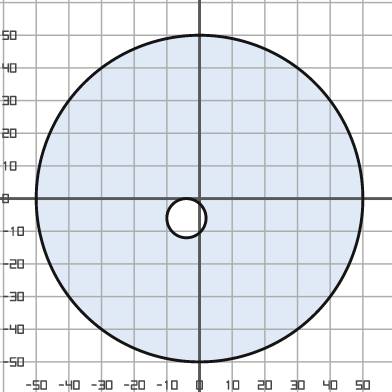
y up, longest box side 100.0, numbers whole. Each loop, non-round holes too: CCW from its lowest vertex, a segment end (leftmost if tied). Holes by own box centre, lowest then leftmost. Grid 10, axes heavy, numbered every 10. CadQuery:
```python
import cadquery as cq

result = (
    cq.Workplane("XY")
    .moveTo(0.0, 0.0)
    .circle(50.0)
    .moveTo(-4.0, -6.0)
    .circle(6.0)
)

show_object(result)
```